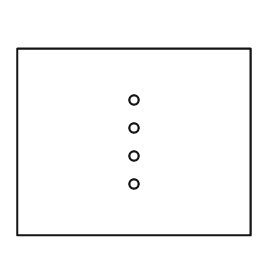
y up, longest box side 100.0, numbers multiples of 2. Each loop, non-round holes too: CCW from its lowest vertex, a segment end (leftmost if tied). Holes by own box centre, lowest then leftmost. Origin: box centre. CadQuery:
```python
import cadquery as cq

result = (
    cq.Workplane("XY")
    .moveTo(-50.0, -40.0)
    .lineTo(50.0, -40.0)
    .lineTo(50.0, 40.0)
    .lineTo(-50.0, 40.0)
    .close()
    .moveTo(0.0, -18.0)
    .circle(2.0)
    .moveTo(0.0, -6.0)
    .circle(2.0)
    .moveTo(0.0, 6.0)
    .circle(2.0)
    .moveTo(0.0, 18.0)
    .circle(2.0)
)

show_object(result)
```